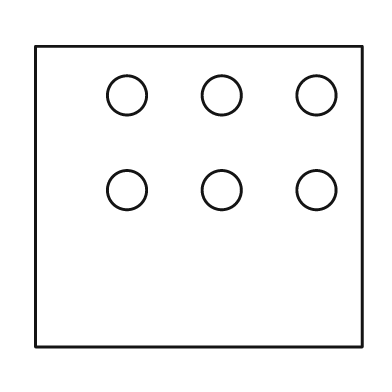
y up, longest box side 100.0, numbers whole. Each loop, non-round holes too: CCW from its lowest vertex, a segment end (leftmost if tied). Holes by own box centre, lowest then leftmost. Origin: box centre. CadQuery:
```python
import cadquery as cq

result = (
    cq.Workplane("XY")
    .moveTo(-50.0, -46.0)
    .lineTo(50.0, -46.0)
    .lineTo(50.0, 46.0)
    .lineTo(-50.0, 46.0)
    .close()
    .moveTo(-22.0, 2.0)
    .circle(6.0)
    .moveTo(7.0, 2.0)
    .circle(6.0)
    .moveTo(36.0, 2.0)
    .circle(6.0)
    .moveTo(-22.0, 31.0)
    .circle(6.0)
    .moveTo(7.0, 31.0)
    .circle(6.0)
    .moveTo(36.0, 31.0)
    .circle(6.0)
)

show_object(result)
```